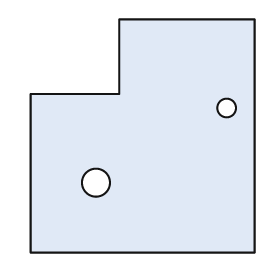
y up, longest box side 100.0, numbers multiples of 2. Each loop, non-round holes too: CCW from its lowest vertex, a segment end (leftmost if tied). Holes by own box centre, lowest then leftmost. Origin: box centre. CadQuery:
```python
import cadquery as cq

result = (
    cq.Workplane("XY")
    .moveTo(-48.0, -50.0)
    .lineTo(48.0, -50.0)
    .lineTo(48.0, 50.0)
    .lineTo(-10.0, 50.0)
    .lineTo(-10.0, 18.0)
    .lineTo(-48.0, 18.0)
    .close()
    .moveTo(-20.0, -20.0)
    .circle(6.0)
    .moveTo(36.0, 12.0)
    .circle(4.0)
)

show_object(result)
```